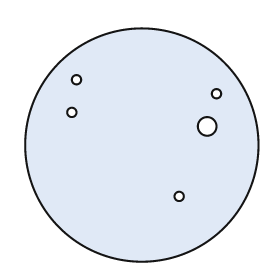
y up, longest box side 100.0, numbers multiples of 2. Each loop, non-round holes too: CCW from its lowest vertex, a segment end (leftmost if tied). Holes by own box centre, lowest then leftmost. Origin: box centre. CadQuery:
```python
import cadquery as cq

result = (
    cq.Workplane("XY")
    .moveTo(0.0, 0.0)
    .circle(50.0)
    .moveTo(16.0, -22.0)
    .circle(2.0)
    .moveTo(28.0, 8.0)
    .circle(4.0)
    .moveTo(-30.0, 14.0)
    .circle(2.0)
    .moveTo(32.0, 22.0)
    .circle(2.0)
    .moveTo(-28.0, 28.0)
    .circle(2.0)
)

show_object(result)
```